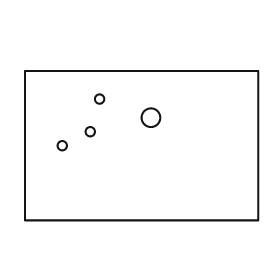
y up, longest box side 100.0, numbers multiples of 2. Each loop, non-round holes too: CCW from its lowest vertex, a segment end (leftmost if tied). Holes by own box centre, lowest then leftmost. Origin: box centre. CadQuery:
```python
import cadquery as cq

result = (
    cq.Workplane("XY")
    .moveTo(-50.0, -32.0)
    .lineTo(50.0, -32.0)
    .lineTo(50.0, 32.0)
    .lineTo(-50.0, 32.0)
    .close()
    .moveTo(-34.0, 0.0)
    .circle(2.0)
    .moveTo(-22.0, 6.0)
    .circle(2.0)
    .moveTo(4.0, 12.0)
    .circle(4.0)
    .moveTo(-18.0, 20.0)
    .circle(2.0)
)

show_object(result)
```